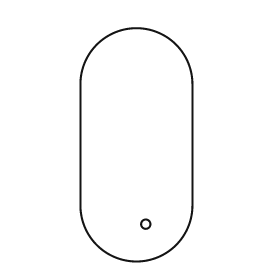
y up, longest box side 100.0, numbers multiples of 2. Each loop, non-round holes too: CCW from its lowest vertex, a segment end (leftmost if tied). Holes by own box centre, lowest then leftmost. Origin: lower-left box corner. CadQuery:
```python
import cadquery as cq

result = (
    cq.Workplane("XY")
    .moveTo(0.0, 24.0)
    .threePointArc((24.0, 0.0), (48.0, 24.0))
    .lineTo(48.0, 76.0)
    .threePointArc((24.0, 100.0), (0.0, 76.0))
    .close()
    .moveTo(28.0, 16.0)
    .circle(2.0)
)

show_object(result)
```